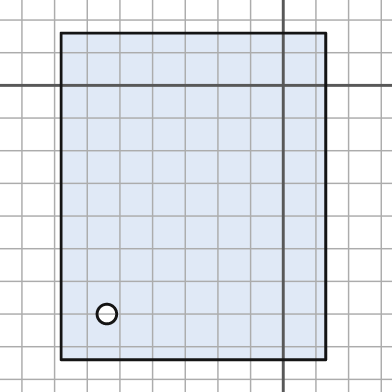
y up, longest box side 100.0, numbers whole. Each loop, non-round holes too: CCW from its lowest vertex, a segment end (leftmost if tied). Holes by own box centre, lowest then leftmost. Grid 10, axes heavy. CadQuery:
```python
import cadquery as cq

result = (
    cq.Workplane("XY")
    .moveTo(-68.0, -84.0)
    .lineTo(13.0, -84.0)
    .lineTo(13.0, 16.0)
    .lineTo(-68.0, 16.0)
    .close()
    .moveTo(-54.0, -70.0)
    .circle(3.0)
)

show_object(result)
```